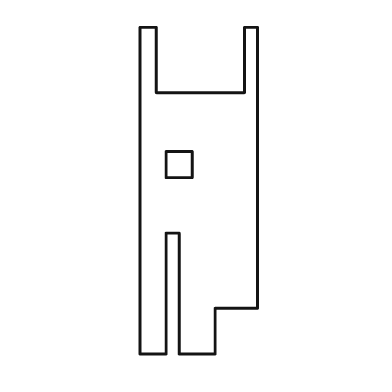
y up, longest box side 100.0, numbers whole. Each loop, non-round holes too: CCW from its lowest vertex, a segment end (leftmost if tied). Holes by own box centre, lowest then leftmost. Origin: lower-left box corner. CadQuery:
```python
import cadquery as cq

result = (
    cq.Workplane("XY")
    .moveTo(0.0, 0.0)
    .lineTo(8.0, 0.0)
    .lineTo(8.0, 37.0)
    .lineTo(12.0, 37.0)
    .lineTo(12.0, 0.0)
    .lineTo(23.0, 0.0)
    .lineTo(23.0, 14.0)
    .lineTo(36.0, 14.0)
    .lineTo(36.0, 100.0)
    .lineTo(32.0, 100.0)
    .lineTo(32.0, 80.0)
    .lineTo(5.0, 80.0)
    .lineTo(5.0, 100.0)
    .lineTo(0.0, 100.0)
    .close()
    .moveTo(8.0, 54.0)
    .lineTo(16.0, 54.0)
    .lineTo(16.0, 62.0)
    .lineTo(8.0, 62.0)
    .close()
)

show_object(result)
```